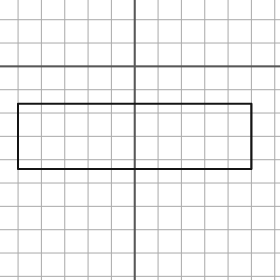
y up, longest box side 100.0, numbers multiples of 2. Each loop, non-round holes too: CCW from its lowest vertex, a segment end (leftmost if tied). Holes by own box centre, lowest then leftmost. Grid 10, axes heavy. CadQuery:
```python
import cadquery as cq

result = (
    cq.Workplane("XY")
    .moveTo(-50.0, -44.0)
    .lineTo(50.0, -44.0)
    .lineTo(50.0, -16.0)
    .lineTo(-50.0, -16.0)
    .close()
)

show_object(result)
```